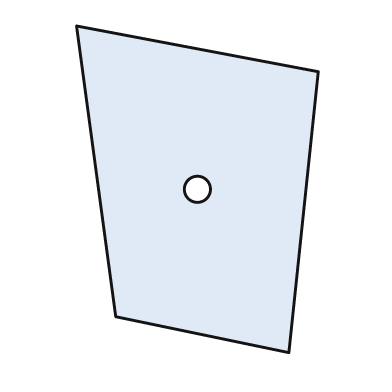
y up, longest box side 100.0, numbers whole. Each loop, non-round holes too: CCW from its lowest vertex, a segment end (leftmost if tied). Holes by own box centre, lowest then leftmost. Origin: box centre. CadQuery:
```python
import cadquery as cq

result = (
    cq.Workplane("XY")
    .moveTo(28.0, -50.0)
    .lineTo(37.0, 36.0)
    .lineTo(-37.0, 50.0)
    .lineTo(-25.0, -39.0)
    .close()
    .moveTo(0.0, 0.0)
    .circle(4.0)
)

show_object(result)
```